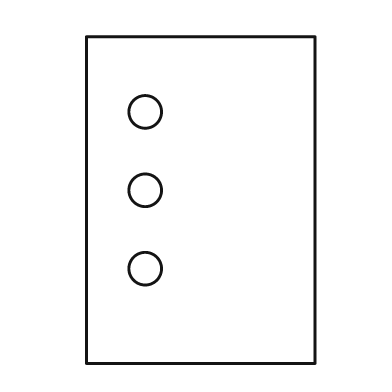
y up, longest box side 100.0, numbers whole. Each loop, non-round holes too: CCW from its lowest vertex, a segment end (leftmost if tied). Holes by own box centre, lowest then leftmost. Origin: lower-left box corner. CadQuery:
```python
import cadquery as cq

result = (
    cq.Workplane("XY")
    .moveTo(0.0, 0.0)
    .lineTo(70.0, 0.0)
    .lineTo(70.0, 100.0)
    .lineTo(0.0, 100.0)
    .close()
    .moveTo(18.0, 29.0)
    .circle(5.0)
    .moveTo(18.0, 53.0)
    .circle(5.0)
    .moveTo(18.0, 77.0)
    .circle(5.0)
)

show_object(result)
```